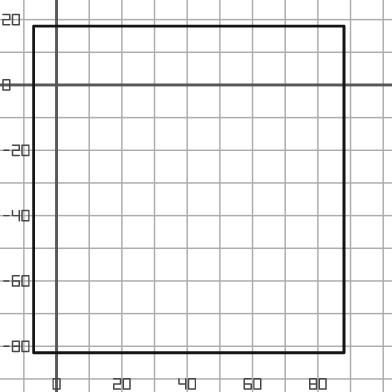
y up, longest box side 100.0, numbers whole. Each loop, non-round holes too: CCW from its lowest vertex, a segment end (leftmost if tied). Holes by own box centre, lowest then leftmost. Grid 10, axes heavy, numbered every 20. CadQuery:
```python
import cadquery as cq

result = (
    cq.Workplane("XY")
    .moveTo(-7.0, -82.0)
    .lineTo(88.0, -82.0)
    .lineTo(88.0, 18.0)
    .lineTo(-7.0, 18.0)
    .close()
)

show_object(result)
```